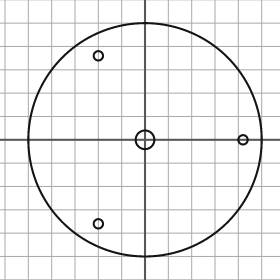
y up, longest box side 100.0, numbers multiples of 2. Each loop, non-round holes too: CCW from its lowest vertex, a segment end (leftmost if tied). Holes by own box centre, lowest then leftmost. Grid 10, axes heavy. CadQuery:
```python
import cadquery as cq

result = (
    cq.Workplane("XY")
    .moveTo(0.0, 0.0)
    .circle(50.0)
    .moveTo(-20.0, -36.0)
    .circle(2.0)
    .moveTo(0.0, 0.0)
    .circle(4.0)
    .moveTo(42.0, 0.0)
    .circle(2.0)
    .moveTo(-20.0, 36.0)
    .circle(2.0)
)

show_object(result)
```